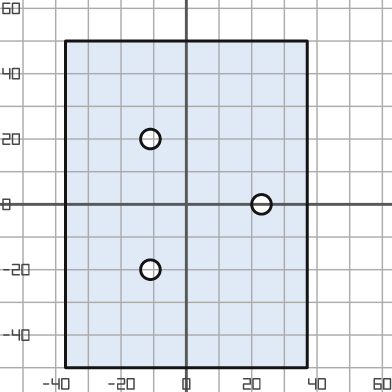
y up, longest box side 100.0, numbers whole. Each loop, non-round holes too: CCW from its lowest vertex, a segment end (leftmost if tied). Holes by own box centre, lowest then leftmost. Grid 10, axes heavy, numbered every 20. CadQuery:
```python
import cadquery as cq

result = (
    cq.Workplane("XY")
    .moveTo(-37.0, -50.0)
    .lineTo(37.0, -50.0)
    .lineTo(37.0, 50.0)
    .lineTo(-37.0, 50.0)
    .close()
    .moveTo(-11.0, -20.0)
    .circle(3.0)
    .moveTo(23.0, 0.0)
    .circle(3.0)
    .moveTo(-11.0, 20.0)
    .circle(3.0)
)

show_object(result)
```